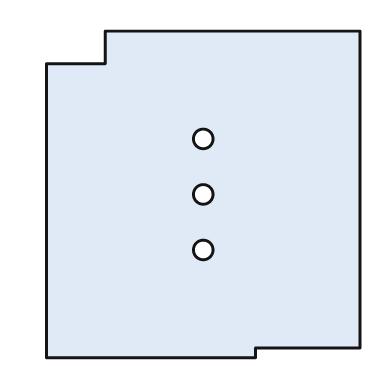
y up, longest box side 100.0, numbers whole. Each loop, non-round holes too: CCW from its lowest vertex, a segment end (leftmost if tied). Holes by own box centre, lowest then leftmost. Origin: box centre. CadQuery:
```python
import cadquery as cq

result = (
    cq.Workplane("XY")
    .moveTo(-48.0, -50.0)
    .lineTo(16.0, -50.0)
    .lineTo(16.0, -47.0)
    .lineTo(48.0, -47.0)
    .lineTo(48.0, 50.0)
    .lineTo(-30.0, 50.0)
    .lineTo(-30.0, 40.0)
    .lineTo(-48.0, 40.0)
    .close()
    .moveTo(0.0, -17.0)
    .circle(3.0)
    .moveTo(0.0, 0.0)
    .circle(3.0)
    .moveTo(0.0, 17.0)
    .circle(3.0)
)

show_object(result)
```